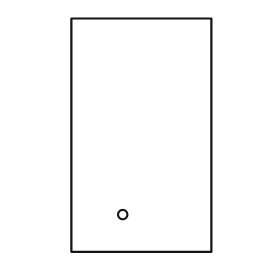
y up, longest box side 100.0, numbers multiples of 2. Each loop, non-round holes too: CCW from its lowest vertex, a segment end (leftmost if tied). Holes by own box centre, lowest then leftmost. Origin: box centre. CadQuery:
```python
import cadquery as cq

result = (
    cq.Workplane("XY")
    .moveTo(-30.0, -50.0)
    .lineTo(30.0, -50.0)
    .lineTo(30.0, 50.0)
    .lineTo(-30.0, 50.0)
    .close()
    .moveTo(-8.0, -34.0)
    .circle(2.0)
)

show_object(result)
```